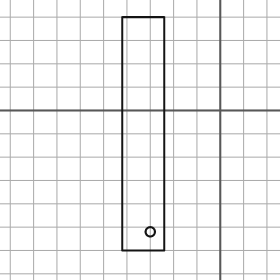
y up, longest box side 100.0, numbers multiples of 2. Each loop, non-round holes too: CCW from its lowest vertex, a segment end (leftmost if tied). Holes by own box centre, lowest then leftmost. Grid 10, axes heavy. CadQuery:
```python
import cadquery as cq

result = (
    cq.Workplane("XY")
    .moveTo(-42.0, -60.0)
    .lineTo(-24.0, -60.0)
    .lineTo(-24.0, 40.0)
    .lineTo(-42.0, 40.0)
    .close()
    .moveTo(-30.0, -52.0)
    .circle(2.0)
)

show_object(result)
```